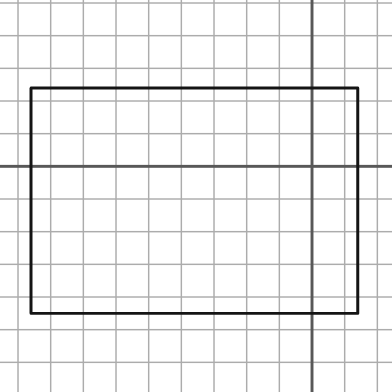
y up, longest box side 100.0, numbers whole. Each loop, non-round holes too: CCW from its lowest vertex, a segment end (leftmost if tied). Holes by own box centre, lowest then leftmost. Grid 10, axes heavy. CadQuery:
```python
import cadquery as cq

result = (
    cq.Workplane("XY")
    .moveTo(-86.0, -45.0)
    .lineTo(14.0, -45.0)
    .lineTo(14.0, 24.0)
    .lineTo(-86.0, 24.0)
    .close()
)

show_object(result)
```